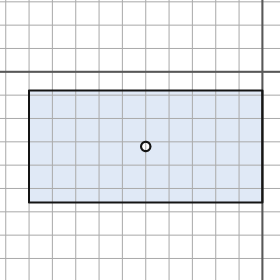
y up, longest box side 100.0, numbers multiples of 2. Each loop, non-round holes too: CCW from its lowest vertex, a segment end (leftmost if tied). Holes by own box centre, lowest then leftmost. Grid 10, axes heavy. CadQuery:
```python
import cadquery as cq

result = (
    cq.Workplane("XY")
    .moveTo(-100.0, -56.0)
    .lineTo(0.0, -56.0)
    .lineTo(0.0, -8.0)
    .lineTo(-100.0, -8.0)
    .close()
    .moveTo(-50.0, -32.0)
    .circle(2.0)
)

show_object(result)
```